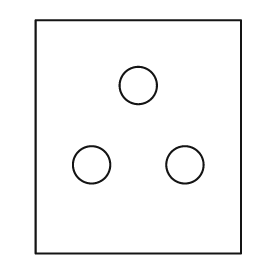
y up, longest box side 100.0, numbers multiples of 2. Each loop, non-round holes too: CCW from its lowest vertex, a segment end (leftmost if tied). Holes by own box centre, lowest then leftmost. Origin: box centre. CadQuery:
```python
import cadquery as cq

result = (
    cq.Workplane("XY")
    .moveTo(-44.0, -50.0)
    .lineTo(44.0, -50.0)
    .lineTo(44.0, 50.0)
    .lineTo(-44.0, 50.0)
    .close()
    .moveTo(-20.0, -12.0)
    .circle(8.0)
    .moveTo(20.0, -12.0)
    .circle(8.0)
    .moveTo(0.0, 22.0)
    .circle(8.0)
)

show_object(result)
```